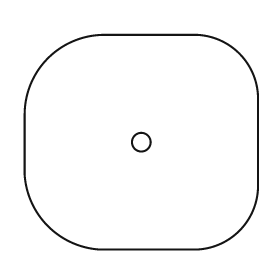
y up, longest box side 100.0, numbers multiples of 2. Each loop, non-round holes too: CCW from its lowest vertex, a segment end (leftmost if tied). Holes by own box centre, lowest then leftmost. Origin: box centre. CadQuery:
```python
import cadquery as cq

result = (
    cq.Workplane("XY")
    .moveTo(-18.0, -46.0)
    .lineTo(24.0, -46.0)
    .threePointArc((42.0, -38.0), (50.0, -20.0))
    .lineTo(50.0, 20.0)
    .threePointArc((42.0, 38.0), (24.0, 46.0))
    .lineTo(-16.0, 46.0)
    .threePointArc((-40.0, 36.0), (-50.0, 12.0))
    .lineTo(-50.0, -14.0)
    .threePointArc((-40.0, -36.0), (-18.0, -46.0))
    .close()
    .moveTo(0.0, 0.0)
    .circle(4.0)
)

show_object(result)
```